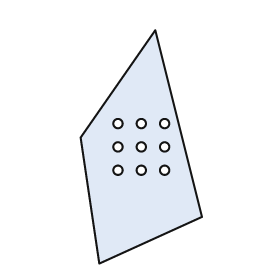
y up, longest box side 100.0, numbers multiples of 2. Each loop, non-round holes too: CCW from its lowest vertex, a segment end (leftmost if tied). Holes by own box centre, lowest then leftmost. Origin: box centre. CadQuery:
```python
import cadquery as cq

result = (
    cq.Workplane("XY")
    .moveTo(-18.0, -50.0)
    .lineTo(26.0, -30.0)
    .lineTo(6.0, 50.0)
    .lineTo(-26.0, 4.0)
    .close()
    .moveTo(-10.0, -10.0)
    .circle(2.0)
    .moveTo(0.0, -10.0)
    .circle(2.0)
    .moveTo(10.0, -10.0)
    .circle(2.0)
    .moveTo(-10.0, 0.0)
    .circle(2.0)
    .moveTo(0.0, 0.0)
    .circle(2.0)
    .moveTo(10.0, 0.0)
    .circle(2.0)
    .moveTo(-10.0, 10.0)
    .circle(2.0)
    .moveTo(0.0, 10.0)
    .circle(2.0)
    .moveTo(10.0, 10.0)
    .circle(2.0)
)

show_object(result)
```